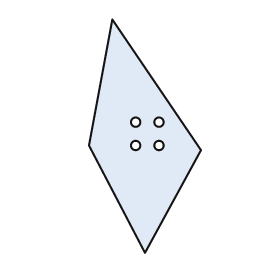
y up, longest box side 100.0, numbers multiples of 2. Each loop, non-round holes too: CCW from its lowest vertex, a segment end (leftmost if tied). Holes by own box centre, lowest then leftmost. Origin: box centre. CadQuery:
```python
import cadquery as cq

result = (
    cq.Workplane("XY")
    .moveTo(0.0, -50.0)
    .lineTo(24.0, -6.0)
    .lineTo(-14.0, 50.0)
    .lineTo(-24.0, -4.0)
    .close()
    .moveTo(-4.0, -4.0)
    .circle(2.0)
    .moveTo(6.0, -4.0)
    .circle(2.0)
    .moveTo(-4.0, 6.0)
    .circle(2.0)
    .moveTo(6.0, 6.0)
    .circle(2.0)
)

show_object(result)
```